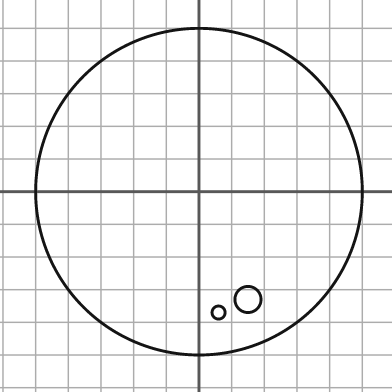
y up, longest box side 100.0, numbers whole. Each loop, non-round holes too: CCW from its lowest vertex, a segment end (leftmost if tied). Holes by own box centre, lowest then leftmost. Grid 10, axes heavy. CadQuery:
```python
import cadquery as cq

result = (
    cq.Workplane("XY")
    .moveTo(0.0, 0.0)
    .circle(50.0)
    .moveTo(6.0, -37.0)
    .circle(2.0)
    .moveTo(15.0, -33.0)
    .circle(4.0)
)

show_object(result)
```